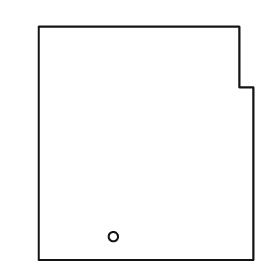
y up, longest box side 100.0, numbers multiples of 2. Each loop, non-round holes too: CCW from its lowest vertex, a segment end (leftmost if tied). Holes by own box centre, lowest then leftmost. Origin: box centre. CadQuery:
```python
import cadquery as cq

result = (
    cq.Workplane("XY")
    .moveTo(-46.0, -50.0)
    .lineTo(46.0, -50.0)
    .lineTo(46.0, 24.0)
    .lineTo(40.0, 24.0)
    .lineTo(40.0, 50.0)
    .lineTo(-46.0, 50.0)
    .close()
    .moveTo(-14.0, -40.0)
    .circle(2.0)
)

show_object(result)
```